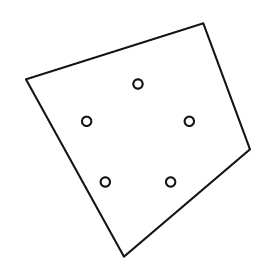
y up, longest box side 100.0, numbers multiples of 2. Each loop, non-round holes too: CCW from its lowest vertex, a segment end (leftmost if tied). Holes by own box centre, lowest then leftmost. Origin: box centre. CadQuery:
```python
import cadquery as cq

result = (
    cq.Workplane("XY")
    .moveTo(-6.0, -50.0)
    .lineTo(48.0, -4.0)
    .lineTo(28.0, 50.0)
    .lineTo(-48.0, 26.0)
    .close()
    .moveTo(-14.0, -18.0)
    .circle(2.0)
    .moveTo(14.0, -18.0)
    .circle(2.0)
    .moveTo(-22.0, 8.0)
    .circle(2.0)
    .moveTo(22.0, 8.0)
    .circle(2.0)
    .moveTo(0.0, 24.0)
    .circle(2.0)
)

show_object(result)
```